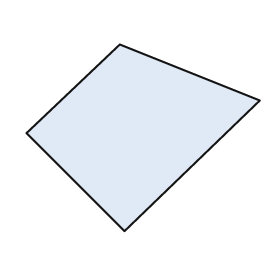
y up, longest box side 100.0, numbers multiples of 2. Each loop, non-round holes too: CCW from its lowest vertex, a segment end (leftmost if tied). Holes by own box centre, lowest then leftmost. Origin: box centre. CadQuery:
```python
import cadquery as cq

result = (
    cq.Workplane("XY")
    .moveTo(-8.0, -40.0)
    .lineTo(50.0, 16.0)
    .lineTo(-10.0, 40.0)
    .lineTo(-50.0, 2.0)
    .close()
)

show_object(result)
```